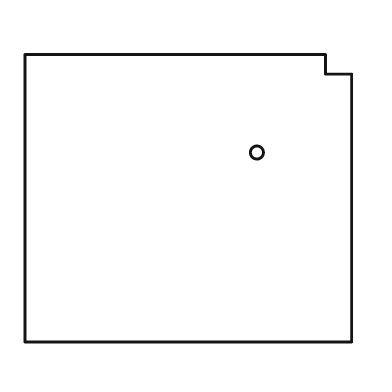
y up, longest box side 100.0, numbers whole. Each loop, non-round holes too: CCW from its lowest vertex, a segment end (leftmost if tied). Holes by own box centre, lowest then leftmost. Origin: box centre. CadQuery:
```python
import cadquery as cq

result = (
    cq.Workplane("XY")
    .moveTo(-50.0, -44.0)
    .lineTo(50.0, -44.0)
    .lineTo(50.0, 38.0)
    .lineTo(42.0, 38.0)
    .lineTo(42.0, 44.0)
    .lineTo(-50.0, 44.0)
    .close()
    .moveTo(21.0, 14.0)
    .circle(2.0)
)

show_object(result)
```